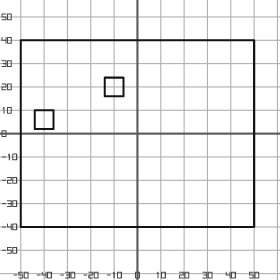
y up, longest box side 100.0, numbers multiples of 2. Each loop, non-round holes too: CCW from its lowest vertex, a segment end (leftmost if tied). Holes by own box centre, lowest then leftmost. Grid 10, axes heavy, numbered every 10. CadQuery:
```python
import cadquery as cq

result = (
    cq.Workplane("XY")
    .moveTo(-50.0, -40.0)
    .lineTo(50.0, -40.0)
    .lineTo(50.0, 40.0)
    .lineTo(-50.0, 40.0)
    .close()
    .moveTo(-44.0, 2.0)
    .lineTo(-36.0, 2.0)
    .lineTo(-36.0, 10.0)
    .lineTo(-44.0, 10.0)
    .close()
    .moveTo(-14.0, 16.0)
    .lineTo(-6.0, 16.0)
    .lineTo(-6.0, 24.0)
    .lineTo(-14.0, 24.0)
    .close()
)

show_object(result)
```